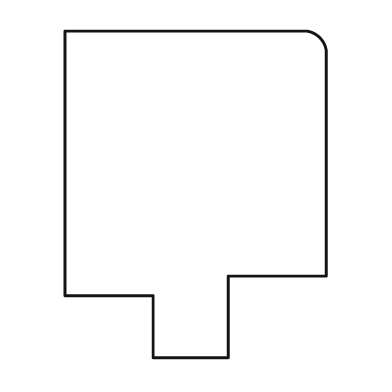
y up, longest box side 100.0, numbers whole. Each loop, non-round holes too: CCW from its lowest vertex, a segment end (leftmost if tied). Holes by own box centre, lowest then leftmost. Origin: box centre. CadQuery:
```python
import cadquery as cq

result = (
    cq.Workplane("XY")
    .moveTo(-13.0, -50.0)
    .lineTo(10.0, -50.0)
    .lineTo(10.0, -25.0)
    .lineTo(40.0, -25.0)
    .lineTo(40.0, 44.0)
    .threePointArc((38.0, 48.0), (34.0, 50.0))
    .lineTo(-40.0, 50.0)
    .lineTo(-40.0, -31.0)
    .lineTo(-13.0, -31.0)
    .close()
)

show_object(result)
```